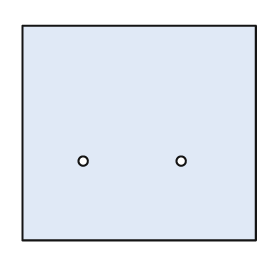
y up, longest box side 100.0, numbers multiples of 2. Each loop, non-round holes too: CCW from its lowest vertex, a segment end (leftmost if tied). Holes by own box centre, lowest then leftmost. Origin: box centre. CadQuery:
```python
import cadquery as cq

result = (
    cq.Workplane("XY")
    .moveTo(-50.0, -46.0)
    .lineTo(50.0, -46.0)
    .lineTo(50.0, 46.0)
    .lineTo(-50.0, 46.0)
    .close()
    .moveTo(-24.0, -12.0)
    .circle(2.0)
    .moveTo(18.0, -12.0)
    .circle(2.0)
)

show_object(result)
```